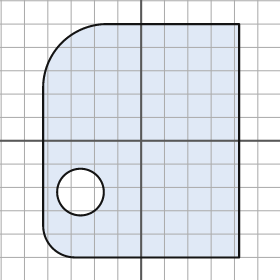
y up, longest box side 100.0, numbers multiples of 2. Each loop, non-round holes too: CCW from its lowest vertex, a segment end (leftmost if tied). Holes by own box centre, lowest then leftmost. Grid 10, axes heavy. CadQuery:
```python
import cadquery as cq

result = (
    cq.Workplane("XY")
    .moveTo(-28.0, -50.0)
    .lineTo(42.0, -50.0)
    .lineTo(42.0, 50.0)
    .lineTo(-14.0, 50.0)
    .threePointArc((-34.0, 42.0), (-42.0, 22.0))
    .lineTo(-42.0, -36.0)
    .threePointArc((-38.0, -46.0), (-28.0, -50.0))
    .close()
    .moveTo(-26.0, -22.0)
    .circle(10.0)
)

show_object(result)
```